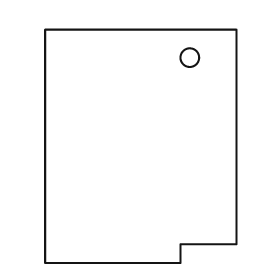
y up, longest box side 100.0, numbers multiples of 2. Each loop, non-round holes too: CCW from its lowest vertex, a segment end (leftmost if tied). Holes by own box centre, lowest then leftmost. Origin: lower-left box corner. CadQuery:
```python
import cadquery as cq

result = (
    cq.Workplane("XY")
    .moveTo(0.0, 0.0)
    .lineTo(58.0, 0.0)
    .lineTo(58.0, 8.0)
    .lineTo(82.0, 8.0)
    .lineTo(82.0, 100.0)
    .lineTo(0.0, 100.0)
    .close()
    .moveTo(62.0, 88.0)
    .circle(4.0)
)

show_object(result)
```